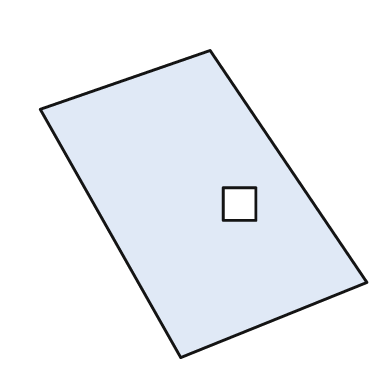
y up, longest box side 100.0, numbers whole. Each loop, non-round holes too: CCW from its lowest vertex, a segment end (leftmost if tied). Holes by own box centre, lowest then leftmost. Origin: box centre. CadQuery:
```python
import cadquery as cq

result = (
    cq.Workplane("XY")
    .moveTo(-7.0, -47.0)
    .lineTo(50.0, -24.0)
    .lineTo(2.0, 47.0)
    .lineTo(-50.0, 29.0)
    .close()
    .moveTo(6.0, -5.0)
    .lineTo(16.0, -5.0)
    .lineTo(16.0, 5.0)
    .lineTo(6.0, 5.0)
    .close()
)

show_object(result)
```